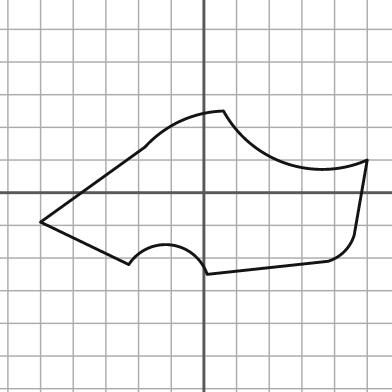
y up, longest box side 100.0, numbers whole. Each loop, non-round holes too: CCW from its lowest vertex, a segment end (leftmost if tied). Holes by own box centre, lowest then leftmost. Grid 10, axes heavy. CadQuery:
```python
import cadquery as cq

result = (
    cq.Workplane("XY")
    .moveTo(1.0, -25.0)
    .lineTo(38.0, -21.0)
    .threePointArc((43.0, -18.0), (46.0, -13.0))
    .lineTo(50.0, 10.0)
    .threePointArc((25.0, 9.0), (6.0, 25.0))
    .threePointArc((-7.0, 22.0), (-18.0, 14.0))
    .lineTo(-50.0, -9.0)
    .lineTo(-23.0, -22.0)
    .threePointArc((-10.0, -16.0), (1.0, -25.0))
    .close()
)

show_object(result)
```